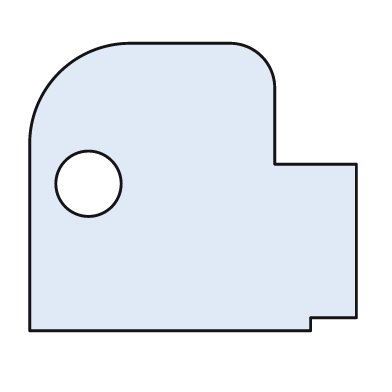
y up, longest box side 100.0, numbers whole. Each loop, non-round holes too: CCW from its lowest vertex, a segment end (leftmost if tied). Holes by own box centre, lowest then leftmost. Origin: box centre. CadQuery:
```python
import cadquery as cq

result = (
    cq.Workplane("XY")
    .moveTo(-50.0, -44.0)
    .lineTo(36.0, -44.0)
    .lineTo(36.0, -40.0)
    .lineTo(50.0, -40.0)
    .lineTo(50.0, 7.0)
    .lineTo(25.0, 7.0)
    .lineTo(25.0, 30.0)
    .threePointArc((21.0, 40.0), (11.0, 44.0))
    .lineTo(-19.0, 44.0)
    .threePointArc((-41.0, 35.0), (-50.0, 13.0))
    .close()
    .moveTo(-32.0, 1.0)
    .circle(10.0)
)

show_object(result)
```